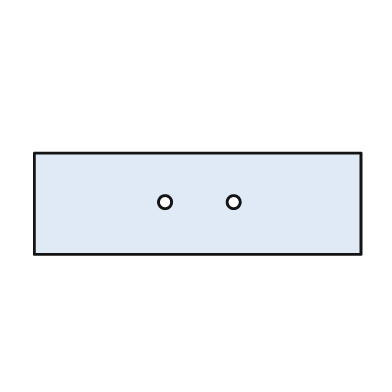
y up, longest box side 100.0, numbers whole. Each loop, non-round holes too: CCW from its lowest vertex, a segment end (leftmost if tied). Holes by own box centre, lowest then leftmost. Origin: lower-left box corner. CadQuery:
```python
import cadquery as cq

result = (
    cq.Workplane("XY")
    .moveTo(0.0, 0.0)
    .lineTo(100.0, 0.0)
    .lineTo(100.0, 31.0)
    .lineTo(0.0, 31.0)
    .close()
    .moveTo(40.0, 16.0)
    .circle(2.0)
    .moveTo(61.0, 16.0)
    .circle(2.0)
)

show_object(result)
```